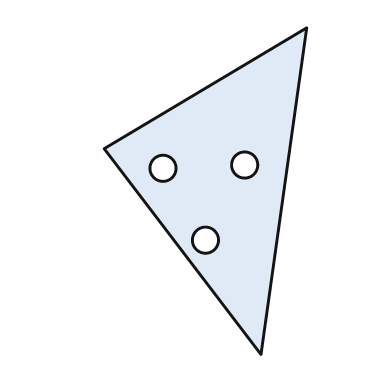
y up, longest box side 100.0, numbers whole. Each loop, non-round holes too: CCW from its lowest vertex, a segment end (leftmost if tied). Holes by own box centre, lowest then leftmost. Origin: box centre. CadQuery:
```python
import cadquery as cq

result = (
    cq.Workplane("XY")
    .moveTo(17.0, -50.0)
    .lineTo(31.0, 50.0)
    .lineTo(-31.0, 13.0)
    .close()
    .moveTo(0.0, -15.0)
    .circle(4.0)
    .moveTo(-13.0, 7.0)
    .circle(4.0)
    .moveTo(12.0, 8.0)
    .circle(4.0)
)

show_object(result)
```